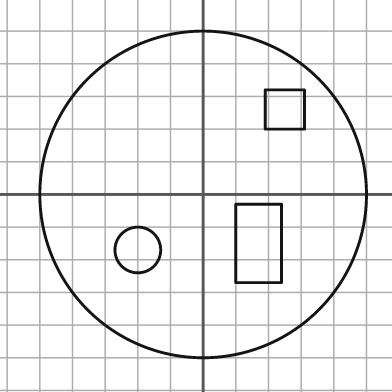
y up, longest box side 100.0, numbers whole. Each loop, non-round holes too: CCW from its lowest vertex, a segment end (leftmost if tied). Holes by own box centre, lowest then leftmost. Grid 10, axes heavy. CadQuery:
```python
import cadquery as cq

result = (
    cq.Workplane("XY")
    .moveTo(0.0, 0.0)
    .circle(50.0)
    .moveTo(-20.0, -17.0)
    .circle(7.0)
    .moveTo(10.0, -27.0)
    .lineTo(24.0, -27.0)
    .lineTo(24.0, -3.0)
    .lineTo(10.0, -3.0)
    .close()
    .moveTo(19.0, 20.0)
    .lineTo(31.0, 20.0)
    .lineTo(31.0, 32.0)
    .lineTo(19.0, 32.0)
    .close()
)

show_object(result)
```